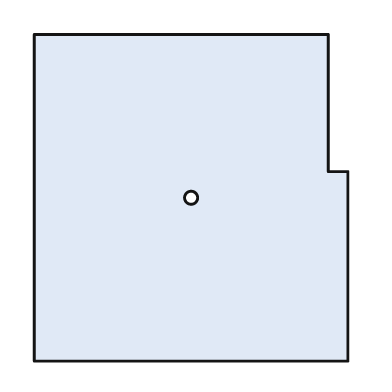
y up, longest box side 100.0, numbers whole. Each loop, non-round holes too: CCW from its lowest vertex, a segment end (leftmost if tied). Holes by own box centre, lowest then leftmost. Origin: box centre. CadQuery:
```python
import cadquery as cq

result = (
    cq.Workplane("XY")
    .moveTo(-48.0, -50.0)
    .lineTo(48.0, -50.0)
    .lineTo(48.0, 8.0)
    .lineTo(42.0, 8.0)
    .lineTo(42.0, 50.0)
    .lineTo(-48.0, 50.0)
    .close()
    .moveTo(0.0, 0.0)
    .circle(2.0)
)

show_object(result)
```